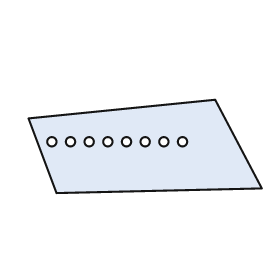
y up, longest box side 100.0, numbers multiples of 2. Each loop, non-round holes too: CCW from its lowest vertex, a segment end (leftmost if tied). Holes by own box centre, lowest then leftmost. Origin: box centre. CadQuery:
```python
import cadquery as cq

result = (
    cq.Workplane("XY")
    .moveTo(-38.0, -20.0)
    .lineTo(50.0, -18.0)
    .lineTo(30.0, 20.0)
    .lineTo(-50.0, 12.0)
    .close()
    .moveTo(-40.0, 2.0)
    .circle(2.0)
    .moveTo(-32.0, 2.0)
    .circle(2.0)
    .moveTo(-24.0, 2.0)
    .circle(2.0)
    .moveTo(-16.0, 2.0)
    .circle(2.0)
    .moveTo(-8.0, 2.0)
    .circle(2.0)
    .moveTo(0.0, 2.0)
    .circle(2.0)
    .moveTo(8.0, 2.0)
    .circle(2.0)
    .moveTo(16.0, 2.0)
    .circle(2.0)
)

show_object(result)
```